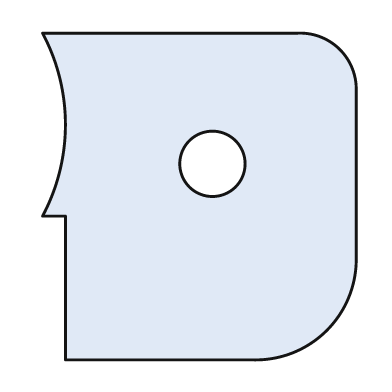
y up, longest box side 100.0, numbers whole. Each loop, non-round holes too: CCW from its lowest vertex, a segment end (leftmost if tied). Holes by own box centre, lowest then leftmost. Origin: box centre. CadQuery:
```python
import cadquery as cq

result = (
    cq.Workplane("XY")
    .moveTo(-41.0, -50.0)
    .lineTo(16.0, -50.0)
    .threePointArc((39.0, -41.0), (48.0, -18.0))
    .lineTo(48.0, 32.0)
    .threePointArc((43.0, 45.0), (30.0, 50.0))
    .lineTo(-48.0, 50.0)
    .threePointArc((-41.0, 22.0), (-48.0, -6.0))
    .lineTo(-41.0, -6.0)
    .close()
    .moveTo(4.0, 10.0)
    .circle(10.0)
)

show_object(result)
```